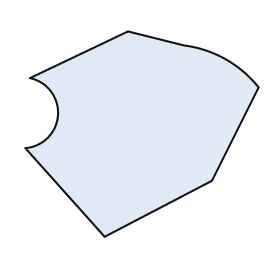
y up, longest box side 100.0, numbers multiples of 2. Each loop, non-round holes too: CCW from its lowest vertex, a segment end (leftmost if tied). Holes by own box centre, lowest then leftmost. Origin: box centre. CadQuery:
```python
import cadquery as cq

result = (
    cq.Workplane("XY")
    .moveTo(-16.0, -44.0)
    .lineTo(30.0, -20.0)
    .lineTo(50.0, 20.0)
    .threePointArc((36.0, 32.0), (18.0, 38.0))
    .lineTo(-6.0, 44.0)
    .lineTo(-48.0, 24.0)
    .threePointArc((-36.0, 8.0), (-50.0, -6.0))
    .close()
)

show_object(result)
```